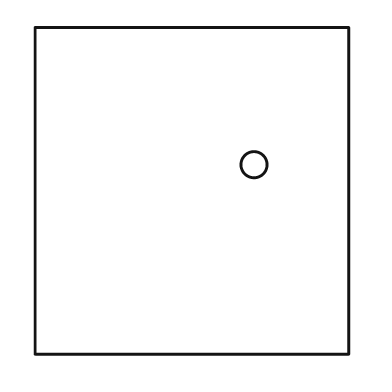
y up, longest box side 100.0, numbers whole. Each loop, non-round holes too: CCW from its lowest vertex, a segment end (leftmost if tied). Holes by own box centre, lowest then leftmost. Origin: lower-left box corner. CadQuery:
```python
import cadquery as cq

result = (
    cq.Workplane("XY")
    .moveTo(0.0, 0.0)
    .lineTo(96.0, 0.0)
    .lineTo(96.0, 100.0)
    .lineTo(0.0, 100.0)
    .close()
    .moveTo(67.0, 58.0)
    .circle(4.0)
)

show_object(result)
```